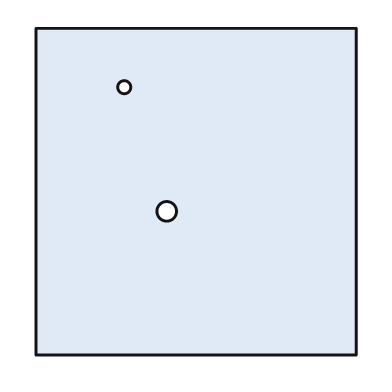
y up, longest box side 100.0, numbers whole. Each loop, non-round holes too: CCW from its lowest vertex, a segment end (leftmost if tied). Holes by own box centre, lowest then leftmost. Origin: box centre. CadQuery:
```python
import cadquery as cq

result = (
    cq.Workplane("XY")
    .moveTo(-49.0, -50.0)
    .lineTo(49.0, -50.0)
    .lineTo(49.0, 50.0)
    .lineTo(-49.0, 50.0)
    .close()
    .moveTo(-9.0, -6.0)
    .circle(3.0)
    .moveTo(-22.0, 32.0)
    .circle(2.0)
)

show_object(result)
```